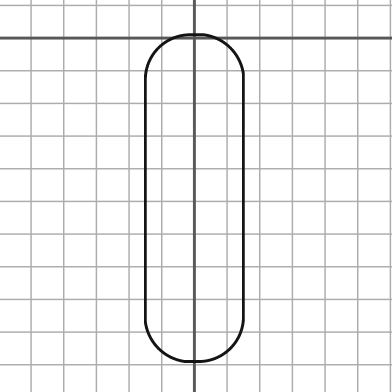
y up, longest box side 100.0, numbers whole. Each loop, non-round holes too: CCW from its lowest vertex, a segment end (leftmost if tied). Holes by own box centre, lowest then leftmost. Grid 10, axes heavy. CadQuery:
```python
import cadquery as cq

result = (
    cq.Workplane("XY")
    .moveTo(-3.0, -99.0)
    .lineTo(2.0, -99.0)
    .threePointArc((11.0, -95.0), (15.0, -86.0))
    .lineTo(15.0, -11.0)
    .threePointArc((11.0, -3.0), (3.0, 1.0))
    .lineTo(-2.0, 1.0)
    .threePointArc((-11.0, -3.0), (-15.0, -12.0))
    .lineTo(-15.0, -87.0)
    .threePointArc((-11.0, -95.0), (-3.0, -99.0))
    .close()
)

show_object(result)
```